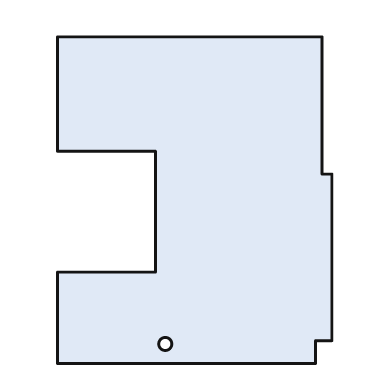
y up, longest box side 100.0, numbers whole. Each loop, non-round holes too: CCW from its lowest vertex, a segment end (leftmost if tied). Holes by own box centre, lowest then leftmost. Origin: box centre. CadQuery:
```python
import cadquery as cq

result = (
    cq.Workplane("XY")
    .moveTo(-42.0, -50.0)
    .lineTo(37.0, -50.0)
    .lineTo(37.0, -43.0)
    .lineTo(42.0, -43.0)
    .lineTo(42.0, 8.0)
    .lineTo(39.0, 8.0)
    .lineTo(39.0, 50.0)
    .lineTo(-42.0, 50.0)
    .lineTo(-42.0, 15.0)
    .lineTo(-12.0, 15.0)
    .lineTo(-12.0, -22.0)
    .lineTo(-42.0, -22.0)
    .close()
    .moveTo(-9.0, -44.0)
    .circle(2.0)
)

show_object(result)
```